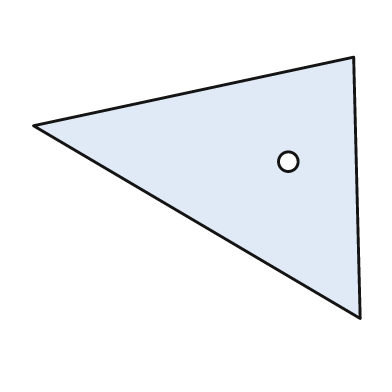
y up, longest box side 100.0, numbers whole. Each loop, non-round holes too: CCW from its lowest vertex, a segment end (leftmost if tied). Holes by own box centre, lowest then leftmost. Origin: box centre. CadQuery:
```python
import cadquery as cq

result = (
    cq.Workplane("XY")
    .moveTo(50.0, -40.0)
    .lineTo(48.0, 40.0)
    .lineTo(-50.0, 19.0)
    .close()
    .moveTo(28.0, 8.0)
    .circle(3.0)
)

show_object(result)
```